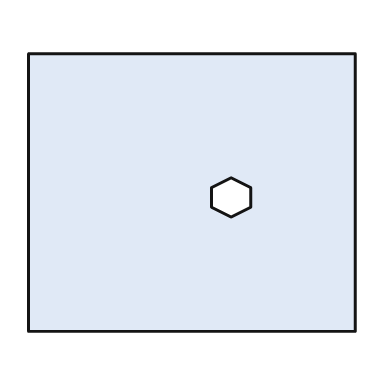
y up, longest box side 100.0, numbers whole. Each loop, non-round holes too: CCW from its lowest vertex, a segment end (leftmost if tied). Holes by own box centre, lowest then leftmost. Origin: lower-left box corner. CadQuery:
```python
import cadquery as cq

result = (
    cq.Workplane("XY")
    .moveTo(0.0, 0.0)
    .lineTo(100.0, 0.0)
    .lineTo(100.0, 85.0)
    .lineTo(0.0, 85.0)
    .close()
    .moveTo(62.0, 35.0)
    .lineTo(68.0, 38.0)
    .lineTo(68.0, 44.0)
    .lineTo(62.0, 47.0)
    .lineTo(56.0, 44.0)
    .lineTo(56.0, 38.0)
    .close()
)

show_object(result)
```